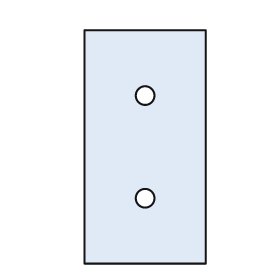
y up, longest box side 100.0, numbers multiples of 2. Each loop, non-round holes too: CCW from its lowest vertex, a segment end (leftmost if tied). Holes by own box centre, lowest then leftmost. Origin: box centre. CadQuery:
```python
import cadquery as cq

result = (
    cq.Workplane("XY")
    .moveTo(-26.0, -50.0)
    .lineTo(26.0, -50.0)
    .lineTo(26.0, 50.0)
    .lineTo(-26.0, 50.0)
    .close()
    .moveTo(0.0, -22.0)
    .circle(4.0)
    .moveTo(0.0, 22.0)
    .circle(4.0)
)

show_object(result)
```